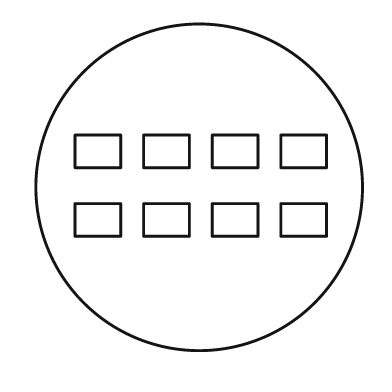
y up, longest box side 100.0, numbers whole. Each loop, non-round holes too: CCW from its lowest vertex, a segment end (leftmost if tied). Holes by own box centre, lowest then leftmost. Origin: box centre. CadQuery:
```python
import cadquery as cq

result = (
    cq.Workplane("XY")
    .moveTo(0.0, 0.0)
    .circle(50.0)
    .moveTo(-38.0, -15.0)
    .lineTo(-24.0, -15.0)
    .lineTo(-24.0, -5.0)
    .lineTo(-38.0, -5.0)
    .close()
    .moveTo(-17.0, -15.0)
    .lineTo(-3.0, -15.0)
    .lineTo(-3.0, -5.0)
    .lineTo(-17.0, -5.0)
    .close()
    .moveTo(4.0, -15.0)
    .lineTo(18.0, -15.0)
    .lineTo(18.0, -5.0)
    .lineTo(4.0, -5.0)
    .close()
    .moveTo(25.0, -15.0)
    .lineTo(39.0, -15.0)
    .lineTo(39.0, -5.0)
    .lineTo(25.0, -5.0)
    .close()
    .moveTo(-38.0, 6.0)
    .lineTo(-24.0, 6.0)
    .lineTo(-24.0, 16.0)
    .lineTo(-38.0, 16.0)
    .close()
    .moveTo(-17.0, 6.0)
    .lineTo(-3.0, 6.0)
    .lineTo(-3.0, 16.0)
    .lineTo(-17.0, 16.0)
    .close()
    .moveTo(4.0, 6.0)
    .lineTo(18.0, 6.0)
    .lineTo(18.0, 16.0)
    .lineTo(4.0, 16.0)
    .close()
    .moveTo(25.0, 6.0)
    .lineTo(39.0, 6.0)
    .lineTo(39.0, 16.0)
    .lineTo(25.0, 16.0)
    .close()
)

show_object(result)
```